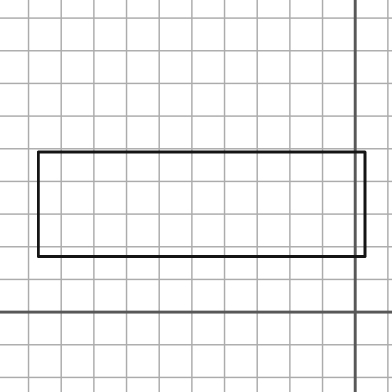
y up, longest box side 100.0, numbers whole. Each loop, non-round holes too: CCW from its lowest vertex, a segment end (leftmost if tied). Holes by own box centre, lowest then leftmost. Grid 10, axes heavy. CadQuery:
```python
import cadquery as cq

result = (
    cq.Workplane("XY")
    .moveTo(-97.0, 17.0)
    .lineTo(3.0, 17.0)
    .lineTo(3.0, 49.0)
    .lineTo(-97.0, 49.0)
    .close()
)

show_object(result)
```